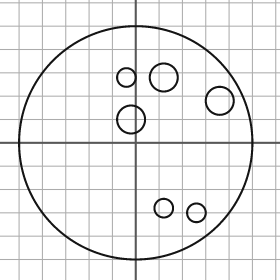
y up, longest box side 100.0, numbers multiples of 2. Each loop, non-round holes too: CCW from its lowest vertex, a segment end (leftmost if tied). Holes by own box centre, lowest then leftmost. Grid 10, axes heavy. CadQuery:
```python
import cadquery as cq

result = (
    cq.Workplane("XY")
    .moveTo(0.0, 0.0)
    .circle(50.0)
    .moveTo(26.0, -30.0)
    .circle(4.0)
    .moveTo(12.0, -28.0)
    .circle(4.0)
    .moveTo(-2.0, 10.0)
    .circle(6.0)
    .moveTo(36.0, 18.0)
    .circle(6.0)
    .moveTo(-4.0, 28.0)
    .circle(4.0)
    .moveTo(12.0, 28.0)
    .circle(6.0)
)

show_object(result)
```